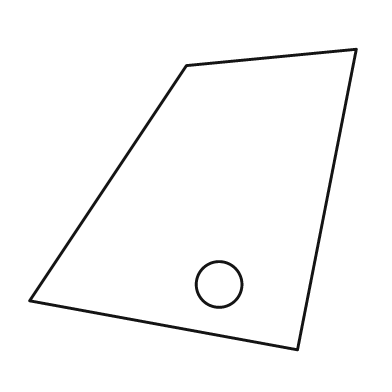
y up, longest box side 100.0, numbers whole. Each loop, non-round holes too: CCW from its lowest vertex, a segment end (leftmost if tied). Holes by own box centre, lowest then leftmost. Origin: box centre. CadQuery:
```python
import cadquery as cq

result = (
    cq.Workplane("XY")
    .moveTo(32.0, -46.0)
    .lineTo(50.0, 46.0)
    .lineTo(-2.0, 41.0)
    .lineTo(-50.0, -31.0)
    .close()
    .moveTo(8.0, -26.0)
    .circle(7.0)
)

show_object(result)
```